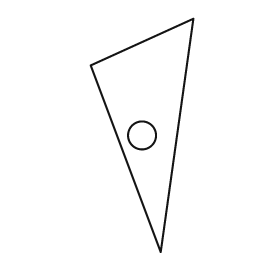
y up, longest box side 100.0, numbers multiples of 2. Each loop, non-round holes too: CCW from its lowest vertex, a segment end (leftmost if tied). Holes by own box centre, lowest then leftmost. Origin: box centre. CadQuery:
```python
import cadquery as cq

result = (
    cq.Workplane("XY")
    .moveTo(8.0, -50.0)
    .lineTo(22.0, 50.0)
    .lineTo(-22.0, 30.0)
    .close()
    .moveTo(0.0, 0.0)
    .circle(6.0)
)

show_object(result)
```